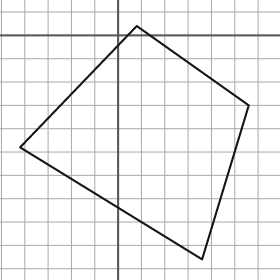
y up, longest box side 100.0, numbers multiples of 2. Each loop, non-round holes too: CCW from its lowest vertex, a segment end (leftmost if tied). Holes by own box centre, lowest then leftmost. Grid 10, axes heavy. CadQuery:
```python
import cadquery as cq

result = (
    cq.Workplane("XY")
    .moveTo(36.0, -96.0)
    .lineTo(56.0, -30.0)
    .lineTo(8.0, 4.0)
    .lineTo(-42.0, -48.0)
    .close()
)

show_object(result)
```